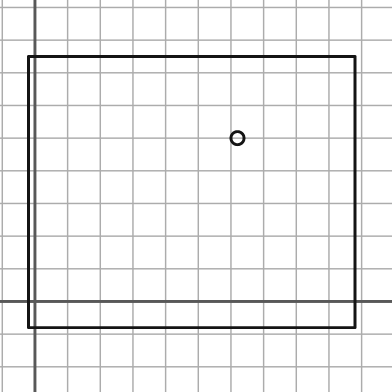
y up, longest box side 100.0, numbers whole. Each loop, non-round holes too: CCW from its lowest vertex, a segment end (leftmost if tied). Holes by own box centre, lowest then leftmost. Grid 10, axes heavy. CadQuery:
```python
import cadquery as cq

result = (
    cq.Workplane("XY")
    .moveTo(-2.0, -8.0)
    .lineTo(98.0, -8.0)
    .lineTo(98.0, 75.0)
    .lineTo(-2.0, 75.0)
    .close()
    .moveTo(62.0, 50.0)
    .circle(2.0)
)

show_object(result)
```